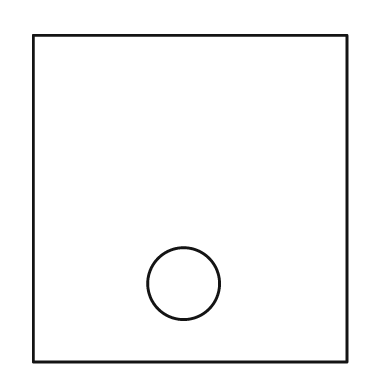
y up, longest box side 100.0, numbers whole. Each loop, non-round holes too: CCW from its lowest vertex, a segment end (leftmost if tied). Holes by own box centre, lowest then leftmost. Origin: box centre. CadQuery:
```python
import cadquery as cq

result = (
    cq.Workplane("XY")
    .moveTo(-48.0, -50.0)
    .lineTo(48.0, -50.0)
    .lineTo(48.0, 50.0)
    .lineTo(-48.0, 50.0)
    .close()
    .moveTo(-2.0, -26.0)
    .circle(11.0)
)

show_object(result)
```